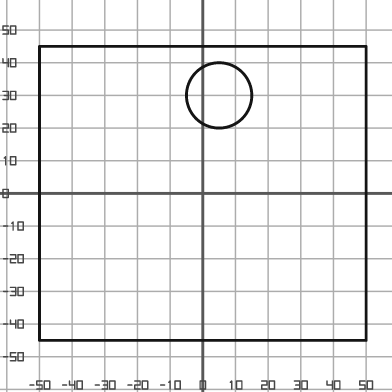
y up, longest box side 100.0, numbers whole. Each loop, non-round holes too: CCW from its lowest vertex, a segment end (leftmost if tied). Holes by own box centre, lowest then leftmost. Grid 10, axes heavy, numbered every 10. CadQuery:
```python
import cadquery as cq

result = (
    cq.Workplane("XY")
    .moveTo(-50.0, -45.0)
    .lineTo(50.0, -45.0)
    .lineTo(50.0, 45.0)
    .lineTo(-50.0, 45.0)
    .close()
    .moveTo(5.0, 30.0)
    .circle(10.0)
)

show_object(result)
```